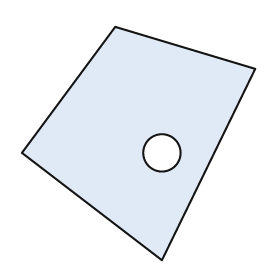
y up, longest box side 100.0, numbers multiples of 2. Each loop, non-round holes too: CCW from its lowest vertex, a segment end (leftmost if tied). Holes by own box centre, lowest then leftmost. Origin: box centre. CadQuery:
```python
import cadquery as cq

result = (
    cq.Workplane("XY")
    .moveTo(10.0, -50.0)
    .lineTo(50.0, 32.0)
    .lineTo(-10.0, 50.0)
    .lineTo(-50.0, -4.0)
    .close()
    .moveTo(10.0, -4.0)
    .circle(8.0)
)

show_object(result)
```